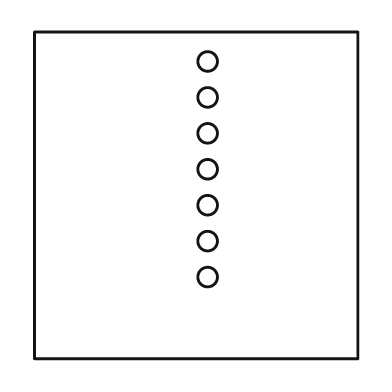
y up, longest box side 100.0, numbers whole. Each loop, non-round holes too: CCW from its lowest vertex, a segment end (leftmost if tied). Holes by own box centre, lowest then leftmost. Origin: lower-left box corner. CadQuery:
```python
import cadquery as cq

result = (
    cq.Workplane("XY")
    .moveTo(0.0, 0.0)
    .lineTo(99.0, 0.0)
    .lineTo(99.0, 100.0)
    .lineTo(0.0, 100.0)
    .close()
    .moveTo(53.0, 25.0)
    .circle(3.0)
    .moveTo(53.0, 36.0)
    .circle(3.0)
    .moveTo(53.0, 47.0)
    .circle(3.0)
    .moveTo(53.0, 58.0)
    .circle(3.0)
    .moveTo(53.0, 69.0)
    .circle(3.0)
    .moveTo(53.0, 80.0)
    .circle(3.0)
    .moveTo(53.0, 91.0)
    .circle(3.0)
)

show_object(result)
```